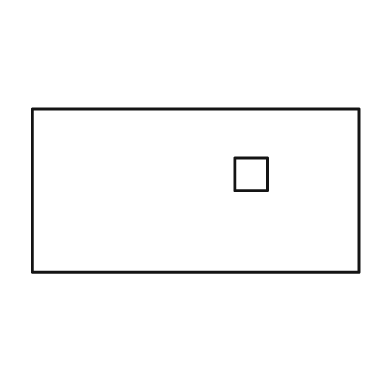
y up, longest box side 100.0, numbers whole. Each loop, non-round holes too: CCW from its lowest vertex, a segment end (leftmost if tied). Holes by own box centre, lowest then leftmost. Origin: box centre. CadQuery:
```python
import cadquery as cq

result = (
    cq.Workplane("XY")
    .moveTo(-50.0, -25.0)
    .lineTo(50.0, -25.0)
    .lineTo(50.0, 25.0)
    .lineTo(-50.0, 25.0)
    .close()
    .moveTo(12.0, 0.0)
    .lineTo(22.0, 0.0)
    .lineTo(22.0, 10.0)
    .lineTo(12.0, 10.0)
    .close()
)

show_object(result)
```